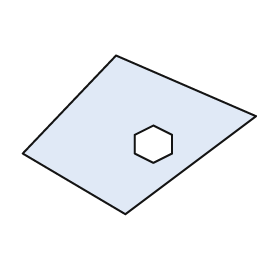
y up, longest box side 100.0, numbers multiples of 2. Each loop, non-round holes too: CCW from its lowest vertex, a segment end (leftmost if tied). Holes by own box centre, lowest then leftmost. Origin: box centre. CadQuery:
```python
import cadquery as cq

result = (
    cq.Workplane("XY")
    .moveTo(-6.0, -34.0)
    .lineTo(50.0, 8.0)
    .lineTo(-10.0, 34.0)
    .lineTo(-50.0, -8.0)
    .close()
    .moveTo(6.0, -12.0)
    .lineTo(14.0, -8.0)
    .lineTo(14.0, 0.0)
    .lineTo(6.0, 4.0)
    .lineTo(-2.0, 0.0)
    .lineTo(-2.0, -8.0)
    .close()
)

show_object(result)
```